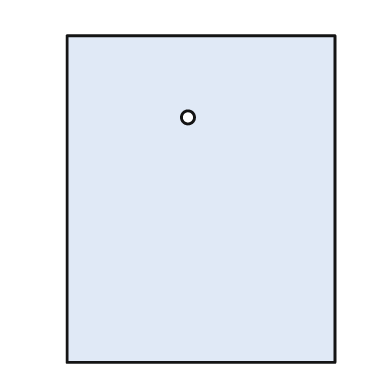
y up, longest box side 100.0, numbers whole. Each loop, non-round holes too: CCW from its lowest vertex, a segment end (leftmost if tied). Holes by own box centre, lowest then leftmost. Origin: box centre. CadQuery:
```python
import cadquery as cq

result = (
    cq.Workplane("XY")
    .moveTo(-41.0, -50.0)
    .lineTo(41.0, -50.0)
    .lineTo(41.0, 50.0)
    .lineTo(-41.0, 50.0)
    .close()
    .moveTo(-4.0, 25.0)
    .circle(2.0)
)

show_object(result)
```